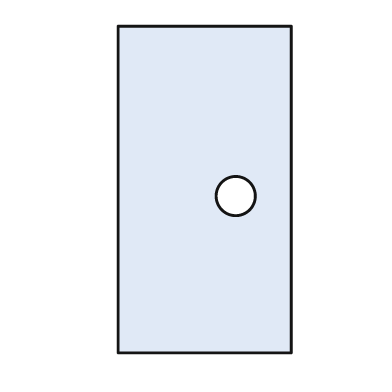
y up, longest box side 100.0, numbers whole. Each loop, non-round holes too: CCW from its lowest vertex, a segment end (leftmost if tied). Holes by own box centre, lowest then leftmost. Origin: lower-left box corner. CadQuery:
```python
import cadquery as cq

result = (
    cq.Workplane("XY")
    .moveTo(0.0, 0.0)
    .lineTo(53.0, 0.0)
    .lineTo(53.0, 100.0)
    .lineTo(0.0, 100.0)
    .close()
    .moveTo(36.0, 48.0)
    .circle(6.0)
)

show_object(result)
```